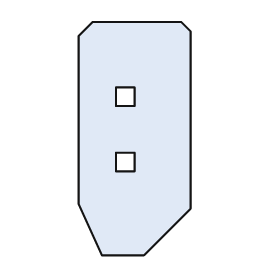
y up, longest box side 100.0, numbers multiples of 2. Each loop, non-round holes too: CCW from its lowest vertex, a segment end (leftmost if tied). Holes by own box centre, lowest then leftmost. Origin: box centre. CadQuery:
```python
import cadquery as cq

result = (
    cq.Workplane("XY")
    .moveTo(-14.0, -50.0)
    .lineTo(4.0, -50.0)
    .lineTo(24.0, -30.0)
    .lineTo(24.0, 46.0)
    .lineTo(20.0, 50.0)
    .lineTo(-18.0, 50.0)
    .lineTo(-24.0, 44.0)
    .lineTo(-24.0, -28.0)
    .close()
    .moveTo(-8.0, -14.0)
    .lineTo(0.0, -14.0)
    .lineTo(0.0, -6.0)
    .lineTo(-8.0, -6.0)
    .close()
    .moveTo(-8.0, 14.0)
    .lineTo(0.0, 14.0)
    .lineTo(0.0, 22.0)
    .lineTo(-8.0, 22.0)
    .close()
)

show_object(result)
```